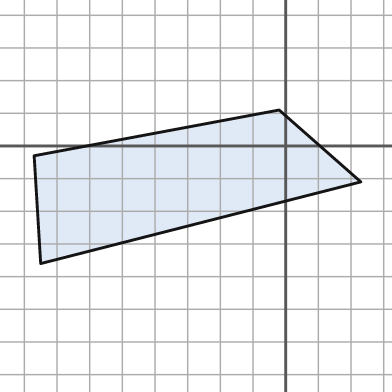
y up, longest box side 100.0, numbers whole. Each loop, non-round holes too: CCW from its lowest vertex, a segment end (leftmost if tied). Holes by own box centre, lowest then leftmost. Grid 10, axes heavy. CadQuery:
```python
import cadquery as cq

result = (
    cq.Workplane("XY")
    .moveTo(-75.0, -36.0)
    .lineTo(23.0, -11.0)
    .lineTo(-2.0, 11.0)
    .lineTo(-77.0, -3.0)
    .close()
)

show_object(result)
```